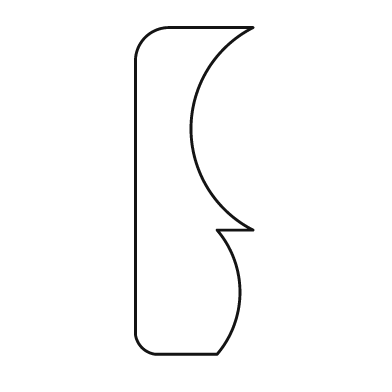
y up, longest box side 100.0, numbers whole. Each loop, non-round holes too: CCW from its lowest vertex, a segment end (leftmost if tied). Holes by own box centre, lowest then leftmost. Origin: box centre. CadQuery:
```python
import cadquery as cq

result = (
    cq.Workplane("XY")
    .moveTo(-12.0, -50.0)
    .lineTo(7.0, -50.0)
    .threePointArc((14.0, -31.0), (7.0, -12.0))
    .lineTo(18.0, -12.0)
    .threePointArc((-1.0, 19.0), (18.0, 50.0))
    .lineTo(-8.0, 50.0)
    .threePointArc((-15.0, 47.0), (-18.0, 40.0))
    .lineTo(-18.0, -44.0)
    .threePointArc((-16.0, -48.0), (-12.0, -50.0))
    .close()
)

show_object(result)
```